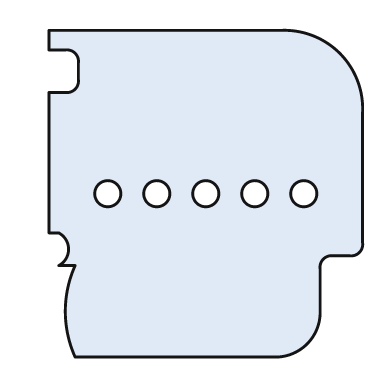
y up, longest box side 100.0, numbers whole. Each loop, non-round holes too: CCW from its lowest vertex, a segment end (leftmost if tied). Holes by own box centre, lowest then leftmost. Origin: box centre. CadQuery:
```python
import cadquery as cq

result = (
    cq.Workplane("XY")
    .moveTo(-40.0, -50.0)
    .lineTo(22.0, -50.0)
    .threePointArc((31.0, -46.0), (35.0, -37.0))
    .lineTo(35.0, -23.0)
    .threePointArc((36.0, -20.0), (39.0, -19.0))
    .lineTo(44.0, -19.0)
    .threePointArc((47.0, -18.0), (48.0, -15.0))
    .lineTo(48.0, 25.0)
    .threePointArc((41.0, 43.0), (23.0, 50.0))
    .lineTo(-48.0, 50.0)
    .lineTo(-48.0, 44.0)
    .lineTo(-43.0, 44.0)
    .threePointArc((-40.0, 43.0), (-39.0, 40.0))
    .lineTo(-39.0, 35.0)
    .threePointArc((-40.0, 32.0), (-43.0, 31.0))
    .lineTo(-48.0, 31.0)
    .lineTo(-48.0, -12.0)
    .lineTo(-45.0, -12.0)
    .threePointArc((-42.0, -17.0), (-45.0, -22.0))
    .lineTo(-40.0, -22.0)
    .threePointArc((-43.0, -36.0), (-40.0, -50.0))
    .close()
    .moveTo(-30.0, 0.0)
    .circle(4.0)
    .moveTo(-15.0, 0.0)
    .circle(4.0)
    .moveTo(0.0, 0.0)
    .circle(4.0)
    .moveTo(15.0, 0.0)
    .circle(4.0)
    .moveTo(30.0, 0.0)
    .circle(4.0)
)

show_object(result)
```